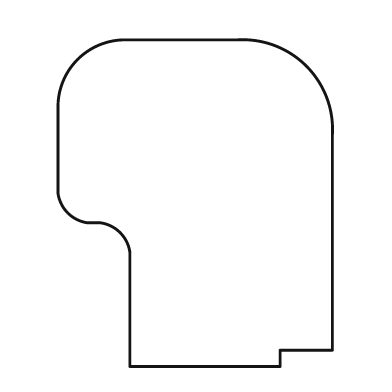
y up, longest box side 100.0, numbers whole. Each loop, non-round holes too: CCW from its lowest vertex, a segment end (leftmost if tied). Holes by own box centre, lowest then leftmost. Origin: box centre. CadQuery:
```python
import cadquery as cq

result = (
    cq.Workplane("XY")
    .moveTo(-20.0, -50.0)
    .lineTo(26.0, -50.0)
    .lineTo(26.0, -45.0)
    .lineTo(42.0, -45.0)
    .lineTo(42.0, 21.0)
    .threePointArc((34.0, 42.0), (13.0, 50.0))
    .lineTo(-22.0, 50.0)
    .threePointArc((-36.0, 44.0), (-42.0, 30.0))
    .lineTo(-42.0, 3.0)
    .threePointArc((-39.0, -3.0), (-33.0, -6.0))
    .lineTo(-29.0, -6.0)
    .threePointArc((-23.0, -9.0), (-20.0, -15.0))
    .close()
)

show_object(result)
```